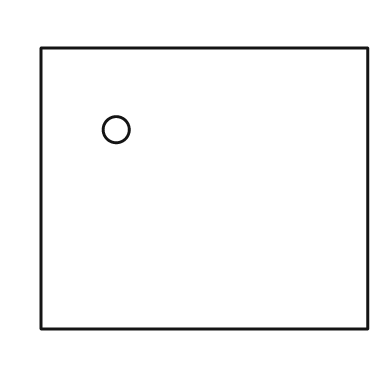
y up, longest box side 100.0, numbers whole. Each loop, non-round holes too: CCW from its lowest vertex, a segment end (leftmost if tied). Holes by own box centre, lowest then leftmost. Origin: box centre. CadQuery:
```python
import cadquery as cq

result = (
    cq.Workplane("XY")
    .moveTo(-50.0, -43.0)
    .lineTo(50.0, -43.0)
    .lineTo(50.0, 43.0)
    .lineTo(-50.0, 43.0)
    .close()
    .moveTo(-27.0, 18.0)
    .circle(4.0)
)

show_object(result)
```